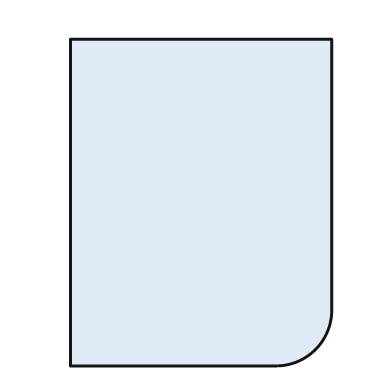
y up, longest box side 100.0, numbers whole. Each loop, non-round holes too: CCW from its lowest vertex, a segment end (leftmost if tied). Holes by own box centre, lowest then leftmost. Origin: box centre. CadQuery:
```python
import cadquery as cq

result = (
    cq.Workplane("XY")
    .moveTo(-40.0, -50.0)
    .lineTo(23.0, -50.0)
    .threePointArc((35.0, -45.0), (40.0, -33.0))
    .lineTo(40.0, 50.0)
    .lineTo(-40.0, 50.0)
    .close()
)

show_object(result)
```